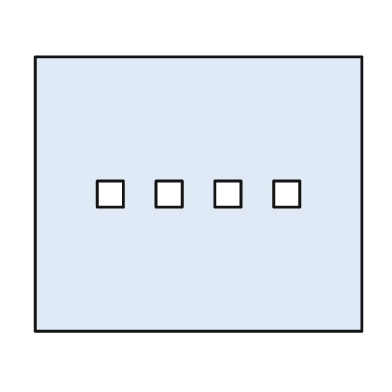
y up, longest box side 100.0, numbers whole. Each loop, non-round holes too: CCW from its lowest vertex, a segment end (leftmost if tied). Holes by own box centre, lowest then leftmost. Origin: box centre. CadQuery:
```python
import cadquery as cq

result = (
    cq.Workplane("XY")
    .moveTo(-50.0, -42.0)
    .lineTo(50.0, -42.0)
    .lineTo(50.0, 42.0)
    .lineTo(-50.0, 42.0)
    .close()
    .moveTo(-31.0, -4.0)
    .lineTo(-23.0, -4.0)
    .lineTo(-23.0, 4.0)
    .lineTo(-31.0, 4.0)
    .close()
    .moveTo(-13.0, -4.0)
    .lineTo(-5.0, -4.0)
    .lineTo(-5.0, 4.0)
    .lineTo(-13.0, 4.0)
    .close()
    .moveTo(5.0, -4.0)
    .lineTo(13.0, -4.0)
    .lineTo(13.0, 4.0)
    .lineTo(5.0, 4.0)
    .close()
    .moveTo(23.0, -4.0)
    .lineTo(31.0, -4.0)
    .lineTo(31.0, 4.0)
    .lineTo(23.0, 4.0)
    .close()
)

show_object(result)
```